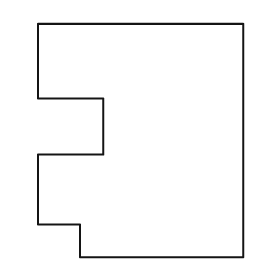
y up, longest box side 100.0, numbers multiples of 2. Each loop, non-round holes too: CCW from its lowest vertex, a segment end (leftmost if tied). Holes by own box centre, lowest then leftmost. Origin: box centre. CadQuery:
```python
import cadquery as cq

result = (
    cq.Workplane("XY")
    .moveTo(-26.0, -50.0)
    .lineTo(44.0, -50.0)
    .lineTo(44.0, 50.0)
    .lineTo(-44.0, 50.0)
    .lineTo(-44.0, 18.0)
    .lineTo(-16.0, 18.0)
    .lineTo(-16.0, -6.0)
    .lineTo(-44.0, -6.0)
    .lineTo(-44.0, -36.0)
    .lineTo(-26.0, -36.0)
    .close()
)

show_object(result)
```